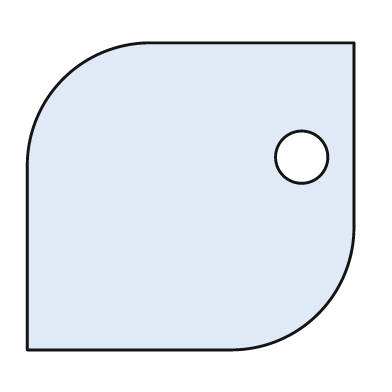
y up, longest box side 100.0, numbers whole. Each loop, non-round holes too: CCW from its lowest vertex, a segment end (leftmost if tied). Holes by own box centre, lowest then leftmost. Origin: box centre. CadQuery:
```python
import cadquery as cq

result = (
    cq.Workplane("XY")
    .moveTo(-50.0, -47.0)
    .lineTo(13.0, -47.0)
    .threePointArc((39.0, -36.0), (50.0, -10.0))
    .lineTo(50.0, 47.0)
    .lineTo(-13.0, 47.0)
    .threePointArc((-39.0, 36.0), (-50.0, 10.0))
    .close()
    .moveTo(34.0, 12.0)
    .circle(8.0)
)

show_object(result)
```